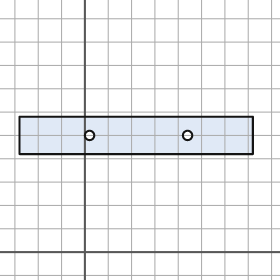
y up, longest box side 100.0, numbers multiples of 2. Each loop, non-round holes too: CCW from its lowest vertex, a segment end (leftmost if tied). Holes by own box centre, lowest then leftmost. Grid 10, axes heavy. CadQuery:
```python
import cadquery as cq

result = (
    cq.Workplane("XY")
    .moveTo(-28.0, 42.0)
    .lineTo(72.0, 42.0)
    .lineTo(72.0, 58.0)
    .lineTo(-28.0, 58.0)
    .close()
    .moveTo(2.0, 50.0)
    .circle(2.0)
    .moveTo(44.0, 50.0)
    .circle(2.0)
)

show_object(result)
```